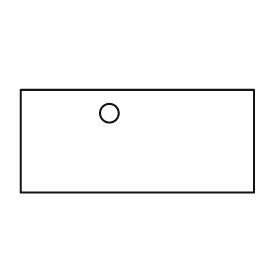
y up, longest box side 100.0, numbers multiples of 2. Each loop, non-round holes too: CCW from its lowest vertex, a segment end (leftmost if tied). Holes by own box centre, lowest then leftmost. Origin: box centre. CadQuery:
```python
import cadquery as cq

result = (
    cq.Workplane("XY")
    .moveTo(-50.0, -22.0)
    .lineTo(50.0, -22.0)
    .lineTo(50.0, 22.0)
    .lineTo(-50.0, 22.0)
    .close()
    .moveTo(-12.0, 12.0)
    .circle(4.0)
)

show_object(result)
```